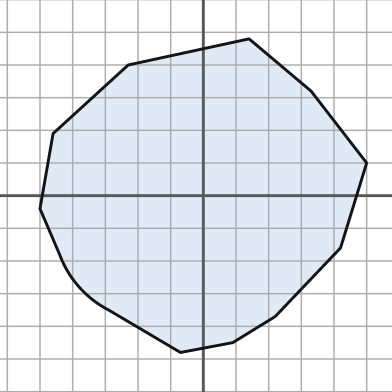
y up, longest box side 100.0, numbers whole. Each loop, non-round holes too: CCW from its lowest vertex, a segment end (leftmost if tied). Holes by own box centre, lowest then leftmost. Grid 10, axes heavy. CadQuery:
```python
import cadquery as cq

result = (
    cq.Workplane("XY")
    .moveTo(-7.0, -48.0)
    .lineTo(9.0, -45.0)
    .lineTo(22.0, -37.0)
    .lineTo(42.0, -16.0)
    .lineTo(50.0, 10.0)
    .lineTo(33.0, 32.0)
    .lineTo(14.0, 48.0)
    .lineTo(-23.0, 40.0)
    .lineTo(-46.0, 19.0)
    .lineTo(-50.0, -4.0)
    .lineTo(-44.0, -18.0)
    .threePointArc((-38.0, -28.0), (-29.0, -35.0))
    .close()
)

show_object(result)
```